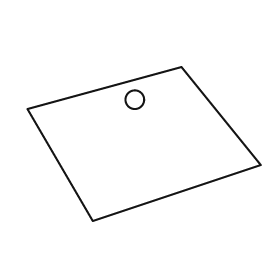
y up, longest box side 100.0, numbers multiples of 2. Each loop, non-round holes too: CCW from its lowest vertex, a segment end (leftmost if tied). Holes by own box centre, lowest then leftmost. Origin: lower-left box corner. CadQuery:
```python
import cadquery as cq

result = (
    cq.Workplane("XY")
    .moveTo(28.0, 0.0)
    .lineTo(100.0, 24.0)
    .lineTo(66.0, 66.0)
    .lineTo(0.0, 48.0)
    .close()
    .moveTo(46.0, 52.0)
    .circle(4.0)
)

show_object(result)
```